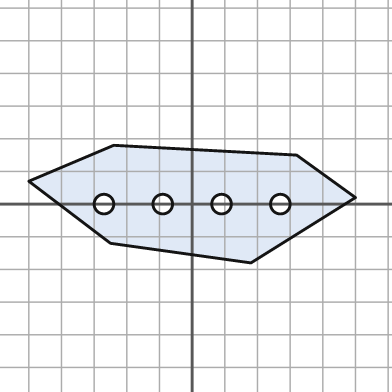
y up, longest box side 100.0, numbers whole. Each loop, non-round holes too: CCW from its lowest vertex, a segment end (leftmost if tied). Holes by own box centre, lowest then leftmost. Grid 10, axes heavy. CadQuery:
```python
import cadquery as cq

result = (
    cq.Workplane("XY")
    .moveTo(18.0, -18.0)
    .lineTo(50.0, 2.0)
    .lineTo(32.0, 15.0)
    .lineTo(-24.0, 18.0)
    .lineTo(-50.0, 7.0)
    .lineTo(-25.0, -12.0)
    .close()
    .moveTo(-27.0, 0.0)
    .circle(3.0)
    .moveTo(-9.0, 0.0)
    .circle(3.0)
    .moveTo(9.0, 0.0)
    .circle(3.0)
    .moveTo(27.0, 0.0)
    .circle(3.0)
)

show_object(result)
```